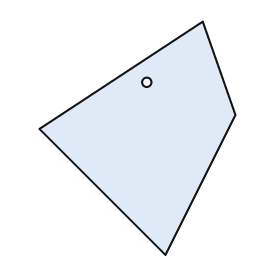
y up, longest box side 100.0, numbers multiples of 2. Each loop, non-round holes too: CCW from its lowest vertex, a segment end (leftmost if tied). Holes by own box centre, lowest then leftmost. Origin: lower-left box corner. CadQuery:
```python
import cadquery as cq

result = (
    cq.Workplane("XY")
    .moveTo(54.0, 0.0)
    .lineTo(84.0, 60.0)
    .lineTo(70.0, 100.0)
    .lineTo(0.0, 54.0)
    .close()
    .moveTo(46.0, 74.0)
    .circle(2.0)
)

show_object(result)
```